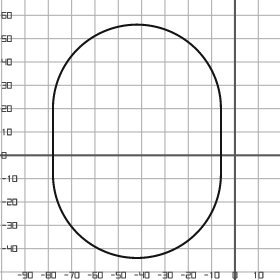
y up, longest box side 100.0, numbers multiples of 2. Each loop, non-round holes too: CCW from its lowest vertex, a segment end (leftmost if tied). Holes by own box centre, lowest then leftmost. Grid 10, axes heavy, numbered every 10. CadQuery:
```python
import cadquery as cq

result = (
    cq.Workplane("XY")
    .moveTo(-78.0, -8.0)
    .threePointArc((-42.0, -44.0), (-6.0, -8.0))
    .lineTo(-6.0, 20.0)
    .threePointArc((-42.0, 56.0), (-78.0, 20.0))
    .close()
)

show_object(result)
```